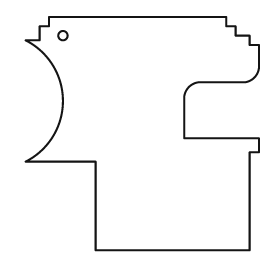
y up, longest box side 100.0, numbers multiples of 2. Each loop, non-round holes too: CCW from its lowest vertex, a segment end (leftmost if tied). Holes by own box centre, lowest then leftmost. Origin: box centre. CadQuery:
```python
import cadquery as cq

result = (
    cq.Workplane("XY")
    .moveTo(-20.0, -50.0)
    .lineTo(46.0, -50.0)
    .lineTo(46.0, -8.0)
    .lineTo(50.0, -8.0)
    .lineTo(50.0, -2.0)
    .lineTo(18.0, -2.0)
    .lineTo(18.0, 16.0)
    .threePointArc((20.0, 20.0), (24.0, 22.0))
    .lineTo(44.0, 22.0)
    .threePointArc((48.0, 24.0), (50.0, 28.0))
    .lineTo(50.0, 38.0)
    .lineTo(46.0, 38.0)
    .lineTo(46.0, 42.0)
    .lineTo(40.0, 42.0)
    .lineTo(40.0, 46.0)
    .lineTo(36.0, 46.0)
    .lineTo(36.0, 50.0)
    .lineTo(-40.0, 50.0)
    .lineTo(-40.0, 46.0)
    .lineTo(-44.0, 46.0)
    .lineTo(-44.0, 40.0)
    .lineTo(-50.0, 40.0)
    .threePointArc((-34.0, 14.0), (-50.0, -12.0))
    .lineTo(-20.0, -12.0)
    .close()
    .moveTo(-34.0, 42.0)
    .circle(2.0)
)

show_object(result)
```